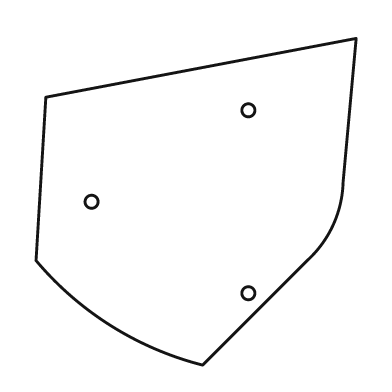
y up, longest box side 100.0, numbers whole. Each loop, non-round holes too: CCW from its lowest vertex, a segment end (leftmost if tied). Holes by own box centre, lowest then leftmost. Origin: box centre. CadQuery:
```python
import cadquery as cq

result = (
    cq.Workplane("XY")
    .moveTo(2.0, -50.0)
    .lineTo(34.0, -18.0)
    .threePointArc((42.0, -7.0), (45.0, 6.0))
    .lineTo(49.0, 50.0)
    .lineTo(-46.0, 32.0)
    .lineTo(-49.0, -18.0)
    .threePointArc((-26.0, -38.0), (2.0, -50.0))
    .close()
    .moveTo(16.0, -28.0)
    .circle(2.0)
    .moveTo(-32.0, 0.0)
    .circle(2.0)
    .moveTo(16.0, 28.0)
    .circle(2.0)
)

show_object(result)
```